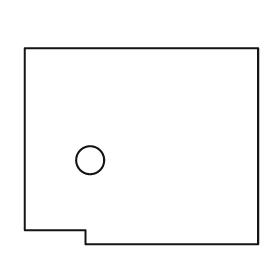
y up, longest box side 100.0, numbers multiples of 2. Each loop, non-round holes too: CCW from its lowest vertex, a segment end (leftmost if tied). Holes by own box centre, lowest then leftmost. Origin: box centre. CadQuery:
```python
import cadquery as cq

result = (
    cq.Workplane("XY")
    .moveTo(-24.0, -42.0)
    .lineTo(50.0, -42.0)
    .lineTo(50.0, 42.0)
    .lineTo(-50.0, 42.0)
    .lineTo(-50.0, -36.0)
    .lineTo(-24.0, -36.0)
    .close()
    .moveTo(-22.0, -6.0)
    .circle(6.0)
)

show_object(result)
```